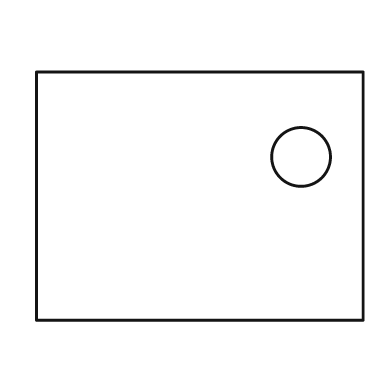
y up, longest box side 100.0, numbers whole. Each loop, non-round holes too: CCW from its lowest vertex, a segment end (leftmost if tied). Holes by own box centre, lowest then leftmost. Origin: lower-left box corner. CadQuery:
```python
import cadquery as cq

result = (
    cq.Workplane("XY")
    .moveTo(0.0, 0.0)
    .lineTo(100.0, 0.0)
    .lineTo(100.0, 76.0)
    .lineTo(0.0, 76.0)
    .close()
    .moveTo(81.0, 50.0)
    .circle(9.0)
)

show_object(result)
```